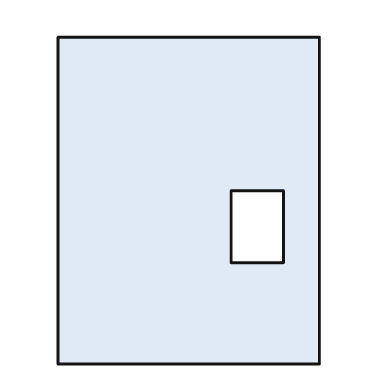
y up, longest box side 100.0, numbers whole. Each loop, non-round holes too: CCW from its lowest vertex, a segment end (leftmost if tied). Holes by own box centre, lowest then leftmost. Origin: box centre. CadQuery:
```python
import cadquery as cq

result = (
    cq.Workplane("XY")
    .moveTo(-40.0, -50.0)
    .lineTo(40.0, -50.0)
    .lineTo(40.0, 50.0)
    .lineTo(-40.0, 50.0)
    .close()
    .moveTo(13.0, -19.0)
    .lineTo(29.0, -19.0)
    .lineTo(29.0, 3.0)
    .lineTo(13.0, 3.0)
    .close()
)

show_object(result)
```